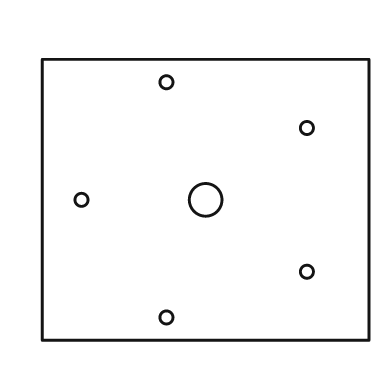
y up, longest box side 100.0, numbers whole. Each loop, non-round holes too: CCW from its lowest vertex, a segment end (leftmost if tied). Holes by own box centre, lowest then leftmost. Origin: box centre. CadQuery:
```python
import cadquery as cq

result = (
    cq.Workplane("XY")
    .moveTo(-50.0, -43.0)
    .lineTo(50.0, -43.0)
    .lineTo(50.0, 43.0)
    .lineTo(-50.0, 43.0)
    .close()
    .moveTo(-12.0, -36.0)
    .circle(2.0)
    .moveTo(31.0, -22.0)
    .circle(2.0)
    .moveTo(-38.0, 0.0)
    .circle(2.0)
    .moveTo(0.0, 0.0)
    .circle(5.0)
    .moveTo(31.0, 22.0)
    .circle(2.0)
    .moveTo(-12.0, 36.0)
    .circle(2.0)
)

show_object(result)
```